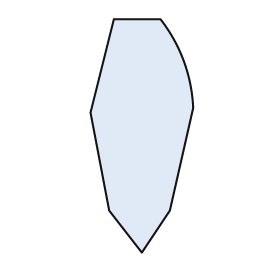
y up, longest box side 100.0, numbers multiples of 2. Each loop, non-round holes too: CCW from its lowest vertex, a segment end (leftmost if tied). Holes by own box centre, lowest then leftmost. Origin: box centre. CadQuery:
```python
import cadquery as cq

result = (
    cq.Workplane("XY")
    .moveTo(0.0, -50.0)
    .lineTo(12.0, -32.0)
    .lineTo(22.0, 12.0)
    .threePointArc((18.0, 32.0), (8.0, 50.0))
    .lineTo(-12.0, 50.0)
    .lineTo(-22.0, 10.0)
    .lineTo(-14.0, -32.0)
    .close()
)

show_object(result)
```